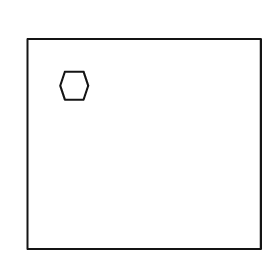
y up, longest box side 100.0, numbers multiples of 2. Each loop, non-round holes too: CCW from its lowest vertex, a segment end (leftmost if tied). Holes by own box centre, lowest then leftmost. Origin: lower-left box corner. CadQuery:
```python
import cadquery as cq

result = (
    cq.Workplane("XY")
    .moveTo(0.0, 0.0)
    .lineTo(100.0, 0.0)
    .lineTo(100.0, 90.0)
    .lineTo(0.0, 90.0)
    .close()
    .moveTo(16.0, 64.0)
    .lineTo(24.0, 64.0)
    .lineTo(26.0, 70.0)
    .lineTo(24.0, 76.0)
    .lineTo(16.0, 76.0)
    .lineTo(14.0, 70.0)
    .close()
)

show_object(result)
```